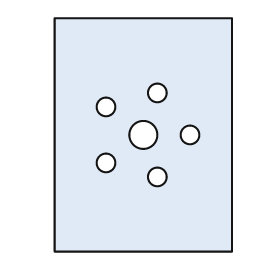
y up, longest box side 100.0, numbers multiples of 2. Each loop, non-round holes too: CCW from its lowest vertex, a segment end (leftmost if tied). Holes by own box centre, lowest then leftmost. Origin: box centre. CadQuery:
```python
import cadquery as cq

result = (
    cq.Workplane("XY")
    .moveTo(-38.0, -50.0)
    .lineTo(38.0, -50.0)
    .lineTo(38.0, 50.0)
    .lineTo(-38.0, 50.0)
    .close()
    .moveTo(6.0, -18.0)
    .circle(4.0)
    .moveTo(-16.0, -12.0)
    .circle(4.0)
    .moveTo(0.0, 0.0)
    .circle(6.0)
    .moveTo(20.0, 0.0)
    .circle(4.0)
    .moveTo(-16.0, 12.0)
    .circle(4.0)
    .moveTo(6.0, 18.0)
    .circle(4.0)
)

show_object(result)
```